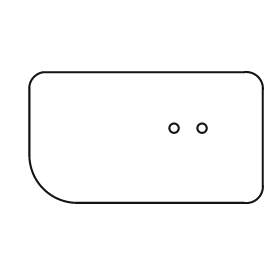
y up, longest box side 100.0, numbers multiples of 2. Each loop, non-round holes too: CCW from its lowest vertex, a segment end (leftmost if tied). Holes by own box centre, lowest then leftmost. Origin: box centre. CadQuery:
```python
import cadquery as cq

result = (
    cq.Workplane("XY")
    .moveTo(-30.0, -28.0)
    .lineTo(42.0, -28.0)
    .threePointArc((48.0, -26.0), (50.0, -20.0))
    .lineTo(50.0, 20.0)
    .threePointArc((48.0, 26.0), (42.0, 28.0))
    .lineTo(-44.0, 28.0)
    .threePointArc((-48.0, 26.0), (-50.0, 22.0))
    .lineTo(-50.0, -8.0)
    .threePointArc((-44.0, -22.0), (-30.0, -28.0))
    .close()
    .moveTo(12.0, 4.0)
    .circle(2.0)
    .moveTo(24.0, 4.0)
    .circle(2.0)
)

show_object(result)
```